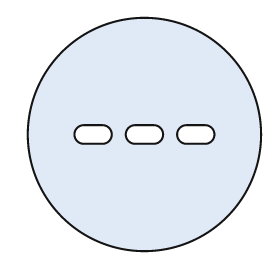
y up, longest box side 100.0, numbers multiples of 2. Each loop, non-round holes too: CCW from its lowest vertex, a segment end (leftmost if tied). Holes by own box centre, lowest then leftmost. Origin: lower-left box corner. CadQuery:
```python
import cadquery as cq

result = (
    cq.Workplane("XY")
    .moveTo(50.0, 50.0)
    .circle(50.0)
    .moveTo(24.0, 46.0)
    .lineTo(32.0, 46.0)
    .threePointArc((36.0, 50.0), (32.0, 54.0))
    .lineTo(24.0, 54.0)
    .threePointArc((20.0, 50.0), (24.0, 46.0))
    .close()
    .moveTo(46.0, 46.0)
    .lineTo(54.0, 46.0)
    .threePointArc((58.0, 50.0), (54.0, 54.0))
    .lineTo(46.0, 54.0)
    .threePointArc((42.0, 50.0), (46.0, 46.0))
    .close()
    .moveTo(68.0, 46.0)
    .lineTo(76.0, 46.0)
    .threePointArc((80.0, 50.0), (76.0, 54.0))
    .lineTo(68.0, 54.0)
    .threePointArc((64.0, 50.0), (68.0, 46.0))
    .close()
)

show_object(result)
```